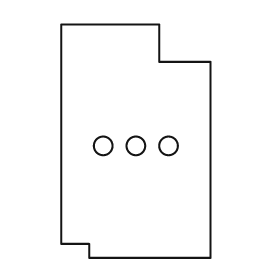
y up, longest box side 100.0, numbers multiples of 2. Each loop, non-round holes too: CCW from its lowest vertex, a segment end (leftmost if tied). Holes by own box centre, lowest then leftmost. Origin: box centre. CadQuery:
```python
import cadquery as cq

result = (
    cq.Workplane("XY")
    .moveTo(-20.0, -50.0)
    .lineTo(32.0, -50.0)
    .lineTo(32.0, 34.0)
    .lineTo(10.0, 34.0)
    .lineTo(10.0, 50.0)
    .lineTo(-32.0, 50.0)
    .lineTo(-32.0, -44.0)
    .lineTo(-20.0, -44.0)
    .close()
    .moveTo(-14.0, -2.0)
    .circle(4.0)
    .moveTo(0.0, -2.0)
    .circle(4.0)
    .moveTo(14.0, -2.0)
    .circle(4.0)
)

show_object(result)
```